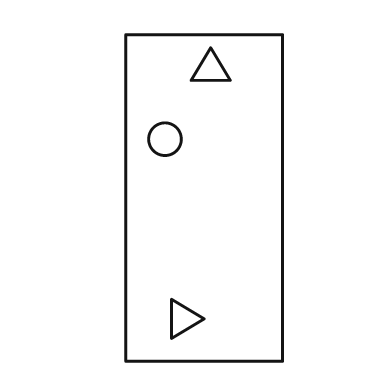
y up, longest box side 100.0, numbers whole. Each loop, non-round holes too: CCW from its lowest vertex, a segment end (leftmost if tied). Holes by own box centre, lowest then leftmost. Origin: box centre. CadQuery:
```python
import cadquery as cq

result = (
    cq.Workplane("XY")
    .moveTo(-24.0, -50.0)
    .lineTo(24.0, -50.0)
    .lineTo(24.0, 50.0)
    .lineTo(-24.0, 50.0)
    .close()
    .moveTo(-10.0, -43.0)
    .lineTo(0.0, -37.0)
    .lineTo(-10.0, -31.0)
    .close()
    .moveTo(-12.0, 18.0)
    .circle(5.0)
    .moveTo(-4.0, 36.0)
    .lineTo(8.0, 36.0)
    .lineTo(2.0, 46.0)
    .close()
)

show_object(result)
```